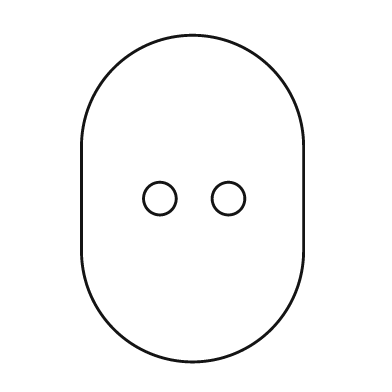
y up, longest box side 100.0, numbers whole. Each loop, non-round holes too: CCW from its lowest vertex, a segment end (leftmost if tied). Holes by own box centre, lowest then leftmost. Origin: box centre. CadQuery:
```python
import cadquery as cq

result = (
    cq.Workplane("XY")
    .moveTo(-34.0, -16.0)
    .threePointArc((0.0, -50.0), (34.0, -16.0))
    .lineTo(34.0, 16.0)
    .threePointArc((0.0, 50.0), (-34.0, 16.0))
    .close()
    .moveTo(-10.0, 0.0)
    .circle(5.0)
    .moveTo(11.0, 0.0)
    .circle(5.0)
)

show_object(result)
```